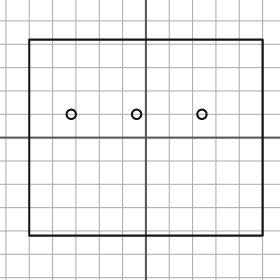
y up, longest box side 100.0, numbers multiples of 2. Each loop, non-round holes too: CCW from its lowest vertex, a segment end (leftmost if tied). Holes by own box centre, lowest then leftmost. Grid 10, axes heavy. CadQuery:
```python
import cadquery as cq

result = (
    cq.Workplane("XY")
    .moveTo(-50.0, -42.0)
    .lineTo(50.0, -42.0)
    .lineTo(50.0, 42.0)
    .lineTo(-50.0, 42.0)
    .close()
    .moveTo(-32.0, 10.0)
    .circle(2.0)
    .moveTo(-4.0, 10.0)
    .circle(2.0)
    .moveTo(24.0, 10.0)
    .circle(2.0)
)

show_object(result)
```